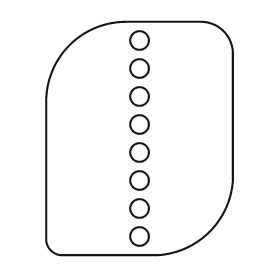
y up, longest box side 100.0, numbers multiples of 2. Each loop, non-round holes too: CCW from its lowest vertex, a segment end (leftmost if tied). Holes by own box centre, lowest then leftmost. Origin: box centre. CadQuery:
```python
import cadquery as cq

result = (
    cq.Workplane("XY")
    .moveTo(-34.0, -50.0)
    .lineTo(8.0, -50.0)
    .threePointArc((30.0, -40.0), (40.0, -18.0))
    .lineTo(40.0, 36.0)
    .threePointArc((36.0, 46.0), (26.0, 50.0))
    .lineTo(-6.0, 50.0)
    .threePointArc((-30.0, 40.0), (-40.0, 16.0))
    .lineTo(-40.0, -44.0)
    .threePointArc((-38.0, -48.0), (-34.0, -50.0))
    .close()
    .moveTo(0.0, -42.0)
    .circle(4.0)
    .moveTo(0.0, -30.0)
    .circle(4.0)
    .moveTo(0.0, -18.0)
    .circle(4.0)
    .moveTo(0.0, -6.0)
    .circle(4.0)
    .moveTo(0.0, 6.0)
    .circle(4.0)
    .moveTo(0.0, 18.0)
    .circle(4.0)
    .moveTo(0.0, 30.0)
    .circle(4.0)
    .moveTo(0.0, 42.0)
    .circle(4.0)
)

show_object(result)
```